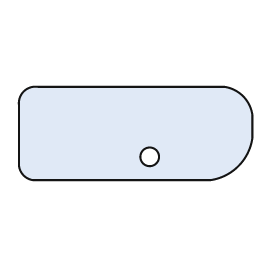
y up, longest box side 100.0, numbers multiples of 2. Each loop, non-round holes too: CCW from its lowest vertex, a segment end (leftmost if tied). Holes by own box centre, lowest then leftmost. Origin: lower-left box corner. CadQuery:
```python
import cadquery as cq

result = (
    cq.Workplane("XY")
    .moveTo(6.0, 0.0)
    .lineTo(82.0, 0.0)
    .threePointArc((94.0, 6.0), (100.0, 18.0))
    .lineTo(100.0, 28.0)
    .threePointArc((96.0, 36.0), (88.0, 40.0))
    .lineTo(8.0, 40.0)
    .threePointArc((2.0, 38.0), (0.0, 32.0))
    .lineTo(0.0, 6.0)
    .threePointArc((2.0, 2.0), (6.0, 0.0))
    .close()
    .moveTo(56.0, 10.0)
    .circle(4.0)
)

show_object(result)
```